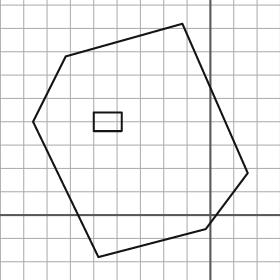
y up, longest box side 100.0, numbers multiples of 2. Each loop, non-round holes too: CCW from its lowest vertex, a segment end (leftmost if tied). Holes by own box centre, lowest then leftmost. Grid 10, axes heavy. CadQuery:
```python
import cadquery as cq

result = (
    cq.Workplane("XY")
    .moveTo(-48.0, -18.0)
    .lineTo(-2.0, -6.0)
    .lineTo(16.0, 18.0)
    .lineTo(-12.0, 82.0)
    .lineTo(-62.0, 68.0)
    .lineTo(-76.0, 40.0)
    .close()
    .moveTo(-50.0, 36.0)
    .lineTo(-38.0, 36.0)
    .lineTo(-38.0, 44.0)
    .lineTo(-50.0, 44.0)
    .close()
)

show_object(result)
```